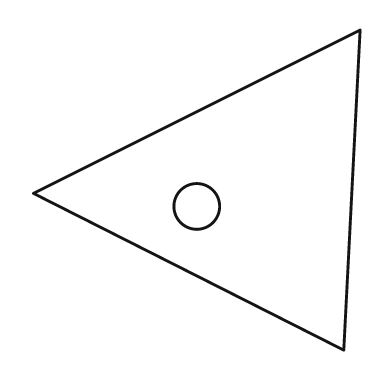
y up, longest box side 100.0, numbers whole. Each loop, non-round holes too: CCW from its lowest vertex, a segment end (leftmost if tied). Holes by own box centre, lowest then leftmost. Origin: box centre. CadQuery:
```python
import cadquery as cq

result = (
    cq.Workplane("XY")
    .moveTo(45.0, -49.0)
    .lineTo(50.0, 49.0)
    .lineTo(-50.0, -1.0)
    .close()
    .moveTo(0.0, -5.0)
    .circle(7.0)
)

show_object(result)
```